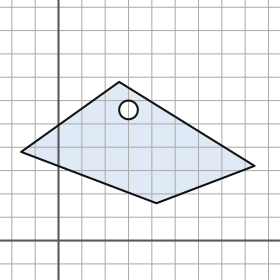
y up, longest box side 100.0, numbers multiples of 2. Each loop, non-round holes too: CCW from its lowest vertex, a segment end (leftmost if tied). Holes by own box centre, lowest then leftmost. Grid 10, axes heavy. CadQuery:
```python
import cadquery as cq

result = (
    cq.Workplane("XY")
    .moveTo(42.0, 16.0)
    .lineTo(84.0, 32.0)
    .lineTo(26.0, 68.0)
    .lineTo(-16.0, 38.0)
    .close()
    .moveTo(30.0, 56.0)
    .circle(4.0)
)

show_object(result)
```